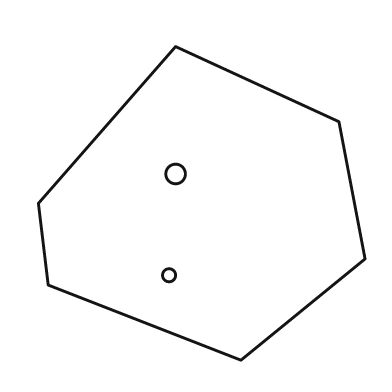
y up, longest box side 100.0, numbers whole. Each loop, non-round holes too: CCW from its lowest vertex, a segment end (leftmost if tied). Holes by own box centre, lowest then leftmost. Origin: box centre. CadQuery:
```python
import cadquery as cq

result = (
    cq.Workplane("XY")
    .moveTo(12.0, -48.0)
    .lineTo(50.0, -17.0)
    .lineTo(42.0, 25.0)
    .lineTo(-8.0, 48.0)
    .lineTo(-50.0, 0.0)
    .lineTo(-47.0, -25.0)
    .close()
    .moveTo(-10.0, -22.0)
    .circle(2.0)
    .moveTo(-8.0, 9.0)
    .circle(3.0)
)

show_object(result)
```